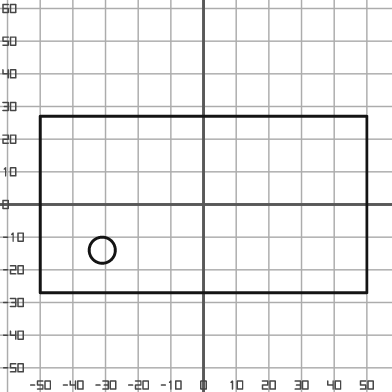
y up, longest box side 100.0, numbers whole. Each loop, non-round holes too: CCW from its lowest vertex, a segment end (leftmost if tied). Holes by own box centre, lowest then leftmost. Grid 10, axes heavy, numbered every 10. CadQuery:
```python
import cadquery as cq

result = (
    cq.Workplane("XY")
    .moveTo(-50.0, -27.0)
    .lineTo(50.0, -27.0)
    .lineTo(50.0, 27.0)
    .lineTo(-50.0, 27.0)
    .close()
    .moveTo(-31.0, -14.0)
    .circle(4.0)
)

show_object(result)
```